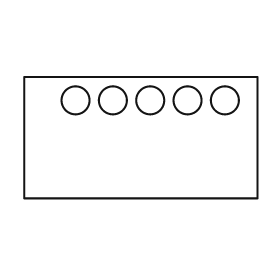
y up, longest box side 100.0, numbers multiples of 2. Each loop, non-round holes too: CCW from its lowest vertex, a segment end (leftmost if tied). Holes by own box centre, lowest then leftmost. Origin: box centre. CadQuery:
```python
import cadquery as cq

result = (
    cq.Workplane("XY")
    .moveTo(-50.0, -26.0)
    .lineTo(50.0, -26.0)
    .lineTo(50.0, 26.0)
    .lineTo(-50.0, 26.0)
    .close()
    .moveTo(-28.0, 16.0)
    .circle(6.0)
    .moveTo(-12.0, 16.0)
    .circle(6.0)
    .moveTo(4.0, 16.0)
    .circle(6.0)
    .moveTo(20.0, 16.0)
    .circle(6.0)
    .moveTo(36.0, 16.0)
    .circle(6.0)
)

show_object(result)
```